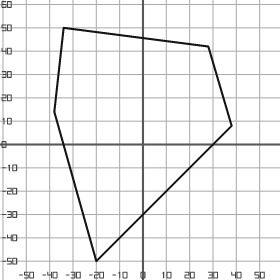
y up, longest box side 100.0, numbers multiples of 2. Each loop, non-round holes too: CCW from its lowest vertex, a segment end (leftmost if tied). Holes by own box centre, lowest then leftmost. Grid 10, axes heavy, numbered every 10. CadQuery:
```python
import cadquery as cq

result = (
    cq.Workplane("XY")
    .moveTo(-20.0, -50.0)
    .lineTo(38.0, 8.0)
    .lineTo(28.0, 42.0)
    .lineTo(-34.0, 50.0)
    .lineTo(-38.0, 14.0)
    .close()
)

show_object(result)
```